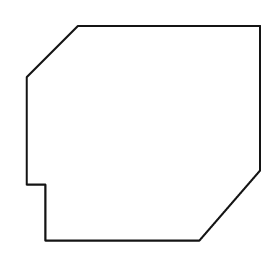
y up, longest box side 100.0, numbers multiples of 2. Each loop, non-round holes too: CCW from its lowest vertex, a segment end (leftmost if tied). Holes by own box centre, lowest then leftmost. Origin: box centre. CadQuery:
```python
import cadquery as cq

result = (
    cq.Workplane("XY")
    .moveTo(-42.0, -46.0)
    .lineTo(24.0, -46.0)
    .lineTo(50.0, -16.0)
    .lineTo(50.0, 46.0)
    .lineTo(-28.0, 46.0)
    .lineTo(-50.0, 24.0)
    .lineTo(-50.0, -22.0)
    .lineTo(-42.0, -22.0)
    .close()
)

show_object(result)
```